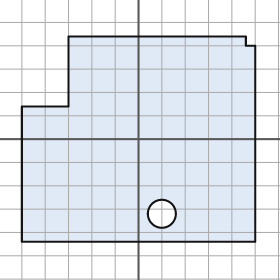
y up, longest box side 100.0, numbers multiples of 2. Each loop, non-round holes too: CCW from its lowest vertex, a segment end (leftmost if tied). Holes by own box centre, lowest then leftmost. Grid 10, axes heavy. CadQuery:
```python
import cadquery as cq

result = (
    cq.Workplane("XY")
    .moveTo(-50.0, -44.0)
    .lineTo(50.0, -44.0)
    .lineTo(50.0, 40.0)
    .lineTo(46.0, 40.0)
    .lineTo(46.0, 44.0)
    .lineTo(-30.0, 44.0)
    .lineTo(-30.0, 14.0)
    .lineTo(-50.0, 14.0)
    .close()
    .moveTo(10.0, -32.0)
    .circle(6.0)
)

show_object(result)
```